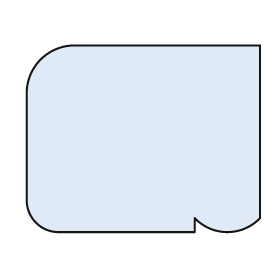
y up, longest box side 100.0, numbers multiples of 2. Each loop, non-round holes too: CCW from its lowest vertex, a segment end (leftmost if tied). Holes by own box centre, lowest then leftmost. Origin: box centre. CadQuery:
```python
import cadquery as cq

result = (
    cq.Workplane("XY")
    .moveTo(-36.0, -40.0)
    .lineTo(22.0, -40.0)
    .lineTo(22.0, -34.0)
    .threePointArc((36.0, -40.0), (50.0, -34.0))
    .lineTo(50.0, 40.0)
    .lineTo(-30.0, 40.0)
    .threePointArc((-44.0, 34.0), (-50.0, 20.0))
    .lineTo(-50.0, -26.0)
    .threePointArc((-46.0, -36.0), (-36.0, -40.0))
    .close()
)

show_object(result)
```